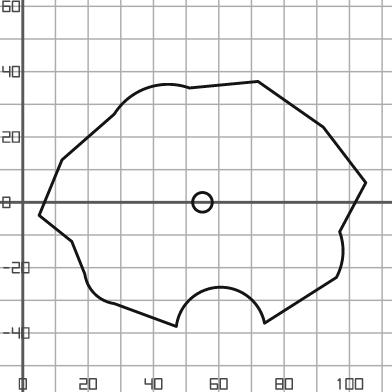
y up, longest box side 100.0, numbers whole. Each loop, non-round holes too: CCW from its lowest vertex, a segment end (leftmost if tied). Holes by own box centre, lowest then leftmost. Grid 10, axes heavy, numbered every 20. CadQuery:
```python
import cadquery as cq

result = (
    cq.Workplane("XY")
    .moveTo(47.0, -38.0)
    .threePointArc((60.0, -26.0), (74.0, -37.0))
    .lineTo(96.0, -23.0)
    .threePointArc((98.0, -16.0), (97.0, -9.0))
    .lineTo(105.0, 6.0)
    .lineTo(92.0, 23.0)
    .lineTo(72.0, 37.0)
    .lineTo(51.0, 35.0)
    .threePointArc((38.0, 35.0), (28.0, 27.0))
    .lineTo(12.0, 13.0)
    .lineTo(5.0, -4.0)
    .lineTo(15.0, -12.0)
    .lineTo(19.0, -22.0)
    .threePointArc((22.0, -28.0), (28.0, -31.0))
    .close()
    .moveTo(55.0, 0.0)
    .circle(3.0)
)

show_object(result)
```